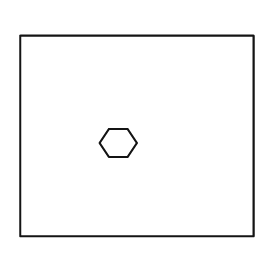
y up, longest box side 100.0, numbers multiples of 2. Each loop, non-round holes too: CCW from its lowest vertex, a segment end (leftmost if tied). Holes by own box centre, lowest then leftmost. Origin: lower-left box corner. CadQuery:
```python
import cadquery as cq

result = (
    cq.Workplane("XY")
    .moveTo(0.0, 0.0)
    .lineTo(100.0, 0.0)
    .lineTo(100.0, 86.0)
    .lineTo(0.0, 86.0)
    .close()
    .moveTo(38.0, 34.0)
    .lineTo(46.0, 34.0)
    .lineTo(50.0, 40.0)
    .lineTo(46.0, 46.0)
    .lineTo(38.0, 46.0)
    .lineTo(34.0, 40.0)
    .close()
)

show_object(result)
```